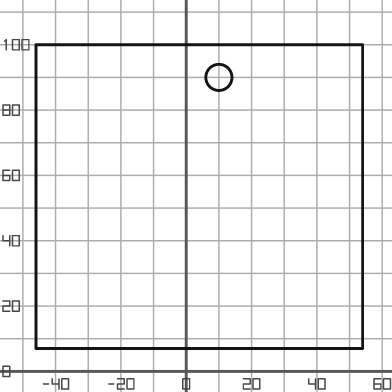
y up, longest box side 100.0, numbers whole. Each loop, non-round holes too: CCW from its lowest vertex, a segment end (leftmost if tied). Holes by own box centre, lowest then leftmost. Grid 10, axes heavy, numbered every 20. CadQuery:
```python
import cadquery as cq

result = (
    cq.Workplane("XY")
    .moveTo(-46.0, 7.0)
    .lineTo(54.0, 7.0)
    .lineTo(54.0, 100.0)
    .lineTo(-46.0, 100.0)
    .close()
    .moveTo(10.0, 90.0)
    .circle(4.0)
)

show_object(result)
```